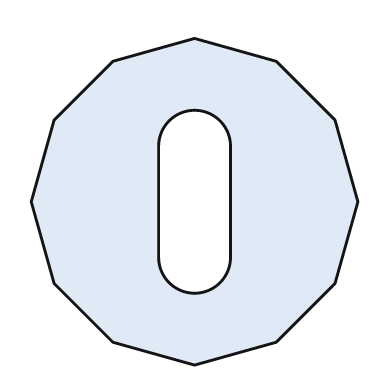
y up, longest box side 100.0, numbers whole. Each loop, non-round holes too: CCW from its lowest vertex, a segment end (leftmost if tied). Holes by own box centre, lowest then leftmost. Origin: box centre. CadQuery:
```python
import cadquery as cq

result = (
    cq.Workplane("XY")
    .moveTo(0.0, -50.0)
    .lineTo(25.0, -43.0)
    .lineTo(43.0, -25.0)
    .lineTo(50.0, 0.0)
    .lineTo(43.0, 25.0)
    .lineTo(25.0, 43.0)
    .lineTo(0.0, 50.0)
    .lineTo(-25.0, 43.0)
    .lineTo(-43.0, 25.0)
    .lineTo(-50.0, 0.0)
    .lineTo(-43.0, -25.0)
    .lineTo(-25.0, -43.0)
    .close()
    .moveTo(-11.0, -17.0)
    .threePointArc((0.0, -28.0), (11.0, -17.0))
    .lineTo(11.0, 17.0)
    .threePointArc((0.0, 28.0), (-11.0, 17.0))
    .close()
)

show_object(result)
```